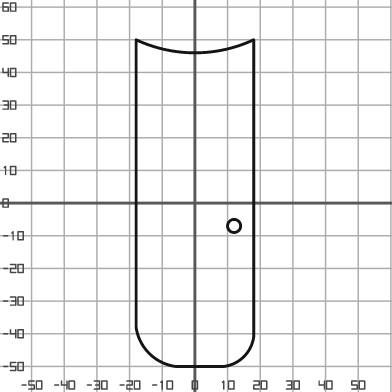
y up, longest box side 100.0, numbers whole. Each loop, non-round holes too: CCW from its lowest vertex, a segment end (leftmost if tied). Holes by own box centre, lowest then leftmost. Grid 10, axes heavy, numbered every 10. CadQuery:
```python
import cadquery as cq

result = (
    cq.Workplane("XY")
    .moveTo(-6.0, -50.0)
    .lineTo(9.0, -50.0)
    .threePointArc((15.0, -47.0), (18.0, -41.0))
    .lineTo(18.0, 50.0)
    .threePointArc((0.0, 46.0), (-18.0, 50.0))
    .lineTo(-18.0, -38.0)
    .threePointArc((-14.0, -46.0), (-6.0, -50.0))
    .close()
    .moveTo(12.0, -7.0)
    .circle(2.0)
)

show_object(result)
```